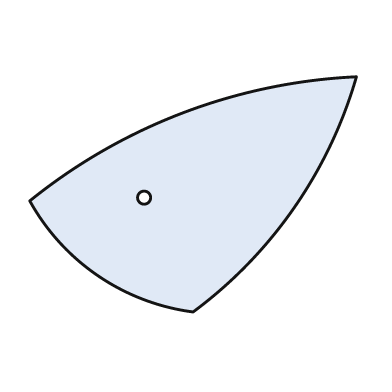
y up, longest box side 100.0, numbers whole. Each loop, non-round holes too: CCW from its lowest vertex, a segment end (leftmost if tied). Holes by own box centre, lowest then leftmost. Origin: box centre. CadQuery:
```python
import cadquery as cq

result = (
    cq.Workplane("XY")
    .moveTo(0.0, -36.0)
    .threePointArc((31.0, -4.0), (50.0, 36.0))
    .threePointArc((-3.0, 25.0), (-50.0, -2.0))
    .threePointArc((-29.0, -25.0), (0.0, -36.0))
    .close()
    .moveTo(-15.0, -1.0)
    .circle(2.0)
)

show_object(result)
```